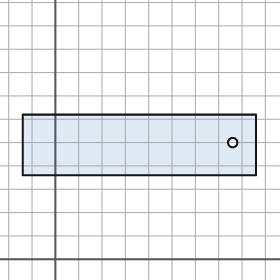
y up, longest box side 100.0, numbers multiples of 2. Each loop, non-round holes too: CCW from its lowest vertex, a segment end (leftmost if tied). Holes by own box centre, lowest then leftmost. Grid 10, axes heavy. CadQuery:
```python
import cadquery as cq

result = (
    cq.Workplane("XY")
    .moveTo(-14.0, 36.0)
    .lineTo(86.0, 36.0)
    .lineTo(86.0, 62.0)
    .lineTo(-14.0, 62.0)
    .close()
    .moveTo(76.0, 50.0)
    .circle(2.0)
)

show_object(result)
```